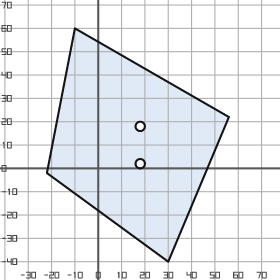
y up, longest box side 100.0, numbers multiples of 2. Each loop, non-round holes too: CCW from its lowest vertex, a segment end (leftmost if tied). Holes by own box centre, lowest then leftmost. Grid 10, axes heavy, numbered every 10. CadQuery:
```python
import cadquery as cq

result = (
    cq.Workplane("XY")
    .moveTo(30.0, -40.0)
    .lineTo(56.0, 22.0)
    .lineTo(-10.0, 60.0)
    .lineTo(-22.0, -2.0)
    .close()
    .moveTo(18.0, 2.0)
    .circle(2.0)
    .moveTo(18.0, 18.0)
    .circle(2.0)
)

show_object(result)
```